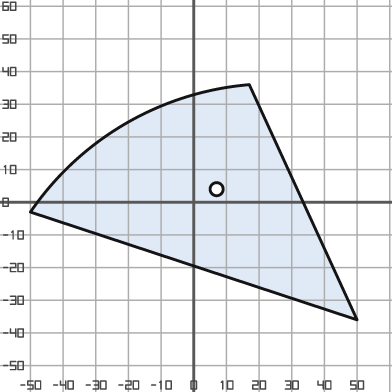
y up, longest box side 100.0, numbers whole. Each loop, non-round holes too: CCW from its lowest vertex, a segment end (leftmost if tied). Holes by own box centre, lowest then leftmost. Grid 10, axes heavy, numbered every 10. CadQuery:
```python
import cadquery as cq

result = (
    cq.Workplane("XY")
    .moveTo(50.0, -36.0)
    .lineTo(17.0, 36.0)
    .threePointArc((-21.0, 24.0), (-50.0, -3.0))
    .close()
    .moveTo(7.0, 4.0)
    .circle(2.0)
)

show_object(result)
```